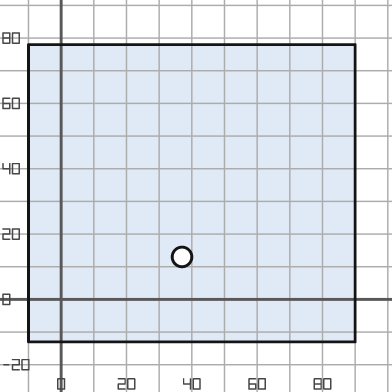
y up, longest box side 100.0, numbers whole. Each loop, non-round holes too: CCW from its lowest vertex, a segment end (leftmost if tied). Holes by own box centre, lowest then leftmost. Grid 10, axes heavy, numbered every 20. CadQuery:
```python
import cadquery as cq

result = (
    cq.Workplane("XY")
    .moveTo(-10.0, -13.0)
    .lineTo(90.0, -13.0)
    .lineTo(90.0, 78.0)
    .lineTo(-10.0, 78.0)
    .close()
    .moveTo(37.0, 13.0)
    .circle(3.0)
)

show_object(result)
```